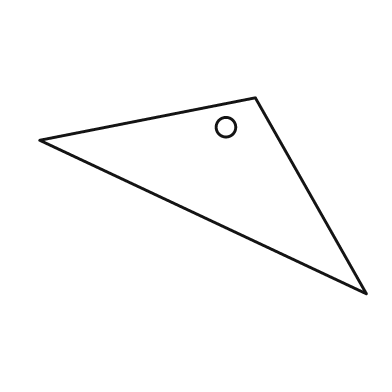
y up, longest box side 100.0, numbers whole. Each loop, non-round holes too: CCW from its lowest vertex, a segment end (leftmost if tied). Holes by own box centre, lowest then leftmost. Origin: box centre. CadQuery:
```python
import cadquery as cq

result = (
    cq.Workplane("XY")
    .moveTo(50.0, -30.0)
    .lineTo(16.0, 30.0)
    .lineTo(-50.0, 17.0)
    .close()
    .moveTo(7.0, 21.0)
    .circle(3.0)
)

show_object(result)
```